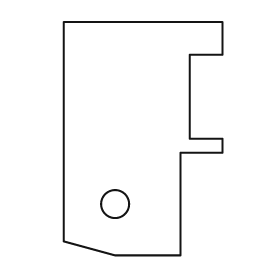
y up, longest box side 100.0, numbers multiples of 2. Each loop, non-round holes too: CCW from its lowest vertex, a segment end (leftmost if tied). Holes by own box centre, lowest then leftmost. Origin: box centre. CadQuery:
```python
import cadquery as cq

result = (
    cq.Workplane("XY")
    .moveTo(-12.0, -50.0)
    .lineTo(16.0, -50.0)
    .lineTo(16.0, -6.0)
    .lineTo(34.0, -6.0)
    .lineTo(34.0, 0.0)
    .lineTo(20.0, 0.0)
    .lineTo(20.0, 36.0)
    .lineTo(34.0, 36.0)
    .lineTo(34.0, 50.0)
    .lineTo(-34.0, 50.0)
    .lineTo(-34.0, -44.0)
    .close()
    .moveTo(-12.0, -28.0)
    .circle(6.0)
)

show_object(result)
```